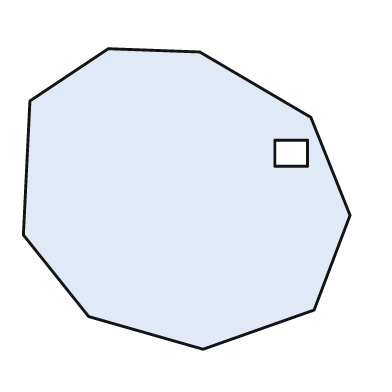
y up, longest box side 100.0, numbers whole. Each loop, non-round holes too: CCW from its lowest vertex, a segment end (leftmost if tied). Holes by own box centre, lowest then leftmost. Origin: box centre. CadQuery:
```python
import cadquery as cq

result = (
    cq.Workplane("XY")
    .moveTo(5.0, -46.0)
    .lineTo(39.0, -34.0)
    .lineTo(50.0, -5.0)
    .lineTo(38.0, 25.0)
    .lineTo(4.0, 45.0)
    .lineTo(-24.0, 46.0)
    .lineTo(-48.0, 30.0)
    .lineTo(-50.0, -11.0)
    .lineTo(-30.0, -36.0)
    .close()
    .moveTo(27.0, 10.0)
    .lineTo(37.0, 10.0)
    .lineTo(37.0, 18.0)
    .lineTo(27.0, 18.0)
    .close()
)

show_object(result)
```